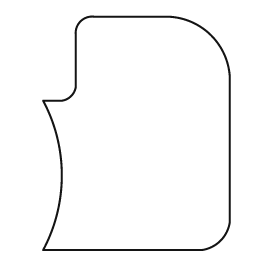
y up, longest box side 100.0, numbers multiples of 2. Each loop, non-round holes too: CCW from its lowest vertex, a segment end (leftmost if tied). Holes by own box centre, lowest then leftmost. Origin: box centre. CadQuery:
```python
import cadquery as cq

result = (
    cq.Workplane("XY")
    .moveTo(-40.0, -50.0)
    .lineTo(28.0, -50.0)
    .threePointArc((36.0, -46.0), (40.0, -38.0))
    .lineTo(40.0, 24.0)
    .threePointArc((32.0, 42.0), (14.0, 50.0))
    .lineTo(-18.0, 50.0)
    .threePointArc((-24.0, 48.0), (-26.0, 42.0))
    .lineTo(-26.0, 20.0)
    .threePointArc((-28.0, 16.0), (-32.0, 14.0))
    .lineTo(-40.0, 14.0)
    .threePointArc((-32.0, -18.0), (-40.0, -50.0))
    .close()
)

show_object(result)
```